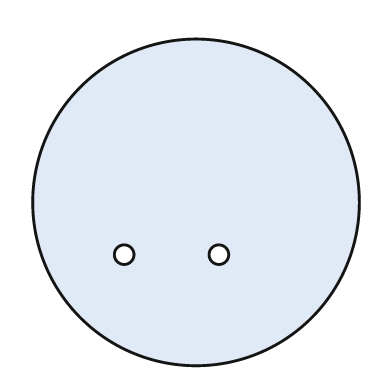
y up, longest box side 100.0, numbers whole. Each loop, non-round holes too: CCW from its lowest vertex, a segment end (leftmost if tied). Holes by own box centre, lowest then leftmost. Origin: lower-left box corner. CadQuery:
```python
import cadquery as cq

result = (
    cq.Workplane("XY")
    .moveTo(50.0, 50.0)
    .circle(50.0)
    .moveTo(28.0, 34.0)
    .circle(3.0)
    .moveTo(57.0, 34.0)
    .circle(3.0)
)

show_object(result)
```